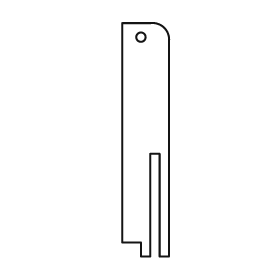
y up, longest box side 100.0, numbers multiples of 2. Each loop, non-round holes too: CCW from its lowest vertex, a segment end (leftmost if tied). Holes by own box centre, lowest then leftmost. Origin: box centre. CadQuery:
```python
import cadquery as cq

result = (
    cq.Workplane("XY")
    .moveTo(-2.0, -50.0)
    .lineTo(2.0, -50.0)
    .lineTo(2.0, -6.0)
    .lineTo(6.0, -6.0)
    .lineTo(6.0, -50.0)
    .lineTo(10.0, -50.0)
    .lineTo(10.0, 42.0)
    .threePointArc((8.0, 48.0), (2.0, 50.0))
    .lineTo(-10.0, 50.0)
    .lineTo(-10.0, -44.0)
    .lineTo(-2.0, -44.0)
    .close()
    .moveTo(-2.0, 44.0)
    .circle(2.0)
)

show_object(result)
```